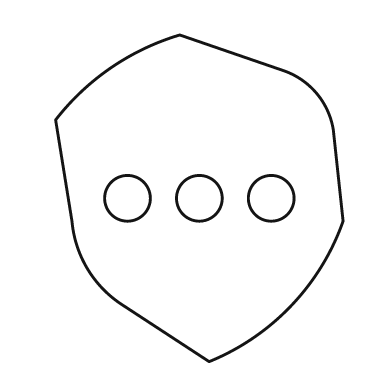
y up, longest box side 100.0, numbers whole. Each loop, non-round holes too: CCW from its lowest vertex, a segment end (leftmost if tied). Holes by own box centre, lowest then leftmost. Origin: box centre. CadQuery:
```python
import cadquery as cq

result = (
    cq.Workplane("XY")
    .moveTo(3.0, -50.0)
    .threePointArc((28.0, -33.0), (44.0, -7.0))
    .lineTo(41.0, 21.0)
    .threePointArc((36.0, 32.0), (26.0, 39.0))
    .lineTo(-6.0, 50.0)
    .threePointArc((-27.0, 40.0), (-44.0, 24.0))
    .lineTo(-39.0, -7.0)
    .threePointArc((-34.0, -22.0), (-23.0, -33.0))
    .close()
    .moveTo(-22.0, 0.0)
    .circle(7.0)
    .moveTo(0.0, 0.0)
    .circle(7.0)
    .moveTo(22.0, 0.0)
    .circle(7.0)
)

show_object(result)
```